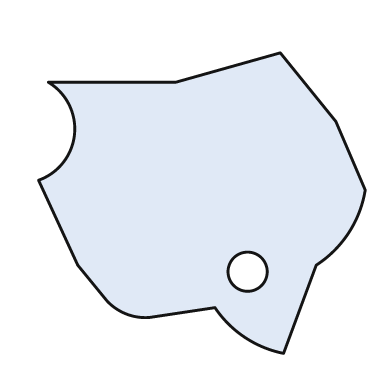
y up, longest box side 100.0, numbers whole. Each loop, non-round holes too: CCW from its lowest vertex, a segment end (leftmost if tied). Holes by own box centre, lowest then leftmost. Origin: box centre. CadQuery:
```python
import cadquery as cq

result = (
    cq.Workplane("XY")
    .moveTo(25.0, -46.0)
    .lineTo(35.0, -19.0)
    .threePointArc((45.0, -9.0), (50.0, 4.0))
    .lineTo(41.0, 25.0)
    .lineTo(24.0, 46.0)
    .lineTo(-8.0, 37.0)
    .lineTo(-47.0, 37.0)
    .threePointArc((-39.0, 21.0), (-50.0, 7.0))
    .lineTo(-38.0, -19.0)
    .lineTo(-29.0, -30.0)
    .threePointArc((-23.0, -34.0), (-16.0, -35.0))
    .lineTo(4.0, -32.0)
    .threePointArc((13.0, -41.0), (25.0, -46.0))
    .close()
    .moveTo(14.0, -21.0)
    .circle(6.0)
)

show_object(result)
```